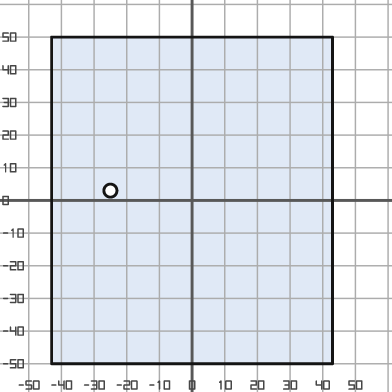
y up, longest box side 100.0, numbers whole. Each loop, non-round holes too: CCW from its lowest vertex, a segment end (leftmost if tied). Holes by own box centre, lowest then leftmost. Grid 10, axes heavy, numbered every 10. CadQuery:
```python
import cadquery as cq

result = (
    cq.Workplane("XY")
    .moveTo(-43.0, -50.0)
    .lineTo(43.0, -50.0)
    .lineTo(43.0, 50.0)
    .lineTo(-43.0, 50.0)
    .close()
    .moveTo(-25.0, 3.0)
    .circle(2.0)
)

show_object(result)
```